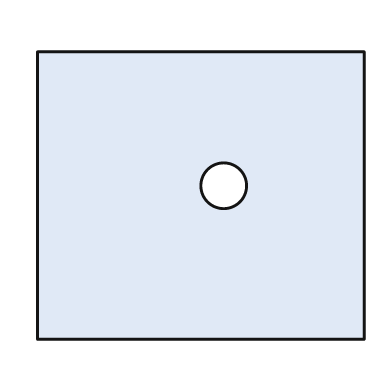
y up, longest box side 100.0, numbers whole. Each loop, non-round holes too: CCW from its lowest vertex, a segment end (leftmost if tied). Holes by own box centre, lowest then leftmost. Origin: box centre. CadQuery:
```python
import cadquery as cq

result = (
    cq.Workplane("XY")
    .moveTo(-50.0, -44.0)
    .lineTo(50.0, -44.0)
    .lineTo(50.0, 44.0)
    .lineTo(-50.0, 44.0)
    .close()
    .moveTo(7.0, 3.0)
    .circle(7.0)
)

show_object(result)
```